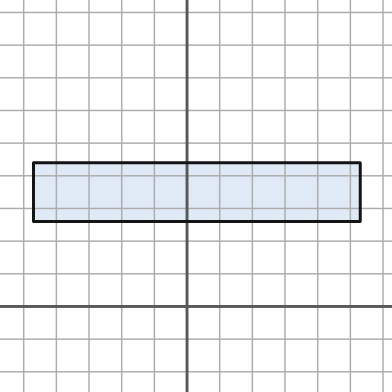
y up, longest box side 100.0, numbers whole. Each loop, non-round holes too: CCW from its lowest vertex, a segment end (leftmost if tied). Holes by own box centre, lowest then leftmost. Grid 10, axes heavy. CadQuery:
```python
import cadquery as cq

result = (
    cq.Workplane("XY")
    .moveTo(-47.0, 26.0)
    .lineTo(53.0, 26.0)
    .lineTo(53.0, 44.0)
    .lineTo(-47.0, 44.0)
    .close()
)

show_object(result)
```